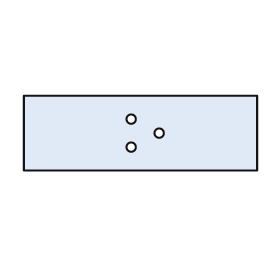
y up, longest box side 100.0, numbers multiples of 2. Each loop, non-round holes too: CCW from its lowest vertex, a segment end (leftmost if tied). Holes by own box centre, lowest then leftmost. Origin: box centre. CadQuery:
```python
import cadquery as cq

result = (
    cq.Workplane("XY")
    .moveTo(-50.0, -16.0)
    .lineTo(50.0, -16.0)
    .lineTo(50.0, 16.0)
    .lineTo(-50.0, 16.0)
    .close()
    .moveTo(-4.0, -6.0)
    .circle(2.0)
    .moveTo(8.0, 0.0)
    .circle(2.0)
    .moveTo(-4.0, 6.0)
    .circle(2.0)
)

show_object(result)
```